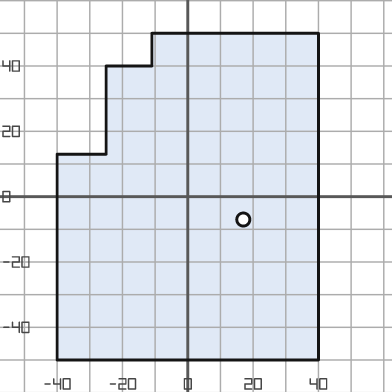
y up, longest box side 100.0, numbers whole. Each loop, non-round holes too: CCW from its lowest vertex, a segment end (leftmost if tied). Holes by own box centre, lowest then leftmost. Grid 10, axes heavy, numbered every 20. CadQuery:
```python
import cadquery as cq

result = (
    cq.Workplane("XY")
    .moveTo(-40.0, -50.0)
    .lineTo(40.0, -50.0)
    .lineTo(40.0, 50.0)
    .lineTo(-11.0, 50.0)
    .lineTo(-11.0, 40.0)
    .lineTo(-25.0, 40.0)
    .lineTo(-25.0, 13.0)
    .lineTo(-40.0, 13.0)
    .close()
    .moveTo(17.0, -7.0)
    .circle(2.0)
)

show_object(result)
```